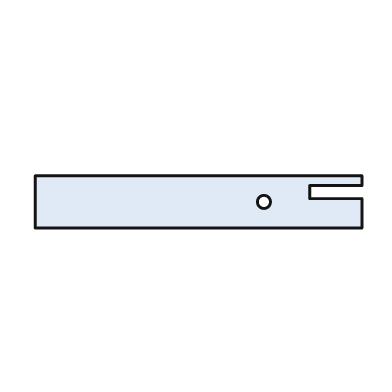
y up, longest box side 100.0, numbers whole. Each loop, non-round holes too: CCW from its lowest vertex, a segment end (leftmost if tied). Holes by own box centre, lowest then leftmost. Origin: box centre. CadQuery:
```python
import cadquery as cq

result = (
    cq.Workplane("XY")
    .moveTo(-50.0, -8.0)
    .lineTo(50.0, -8.0)
    .lineTo(50.0, 1.0)
    .lineTo(34.0, 1.0)
    .lineTo(34.0, 5.0)
    .lineTo(50.0, 5.0)
    .lineTo(50.0, 8.0)
    .lineTo(-50.0, 8.0)
    .close()
    .moveTo(20.0, 0.0)
    .circle(2.0)
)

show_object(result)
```